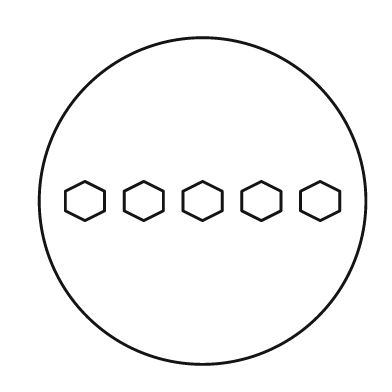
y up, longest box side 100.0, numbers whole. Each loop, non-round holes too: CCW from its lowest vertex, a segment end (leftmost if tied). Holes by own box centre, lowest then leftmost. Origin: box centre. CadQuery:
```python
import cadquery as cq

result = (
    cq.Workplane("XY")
    .moveTo(0.0, 0.0)
    .circle(50.0)
    .moveTo(-36.0, -6.0)
    .lineTo(-30.0, -3.0)
    .lineTo(-30.0, 3.0)
    .lineTo(-36.0, 6.0)
    .lineTo(-42.0, 3.0)
    .lineTo(-42.0, -3.0)
    .close()
    .moveTo(-18.0, -6.0)
    .lineTo(-12.0, -3.0)
    .lineTo(-12.0, 3.0)
    .lineTo(-18.0, 6.0)
    .lineTo(-24.0, 3.0)
    .lineTo(-24.0, -3.0)
    .close()
    .moveTo(0.0, -6.0)
    .lineTo(6.0, -3.0)
    .lineTo(6.0, 3.0)
    .lineTo(0.0, 6.0)
    .lineTo(-6.0, 3.0)
    .lineTo(-6.0, -3.0)
    .close()
    .moveTo(18.0, -6.0)
    .lineTo(24.0, -3.0)
    .lineTo(24.0, 3.0)
    .lineTo(18.0, 6.0)
    .lineTo(12.0, 3.0)
    .lineTo(12.0, -3.0)
    .close()
    .moveTo(36.0, -6.0)
    .lineTo(42.0, -3.0)
    .lineTo(42.0, 3.0)
    .lineTo(36.0, 6.0)
    .lineTo(30.0, 3.0)
    .lineTo(30.0, -3.0)
    .close()
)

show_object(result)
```